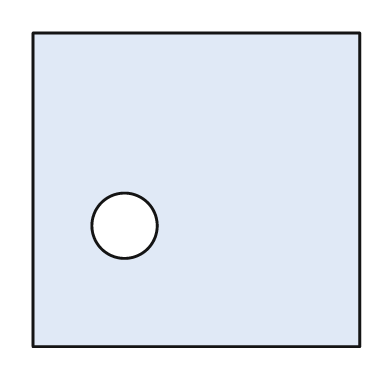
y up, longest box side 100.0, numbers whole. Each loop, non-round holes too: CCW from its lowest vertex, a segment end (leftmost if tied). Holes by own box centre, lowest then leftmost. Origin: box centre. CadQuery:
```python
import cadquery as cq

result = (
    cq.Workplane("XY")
    .moveTo(-50.0, -48.0)
    .lineTo(50.0, -48.0)
    .lineTo(50.0, 48.0)
    .lineTo(-50.0, 48.0)
    .close()
    .moveTo(-22.0, -11.0)
    .circle(10.0)
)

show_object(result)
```